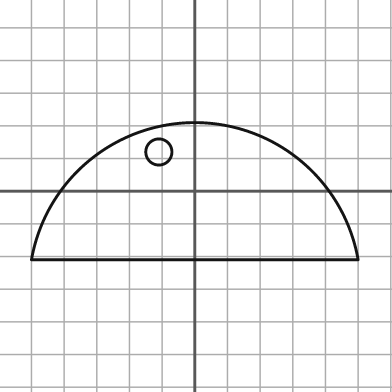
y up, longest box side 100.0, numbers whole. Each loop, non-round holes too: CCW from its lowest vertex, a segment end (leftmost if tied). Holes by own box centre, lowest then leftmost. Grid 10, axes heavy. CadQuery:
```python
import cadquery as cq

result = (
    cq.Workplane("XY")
    .moveTo(-50.0, -21.0)
    .lineTo(50.0, -21.0)
    .threePointArc((0.0, 21.0), (-50.0, -21.0))
    .close()
    .moveTo(-11.0, 12.0)
    .circle(4.0)
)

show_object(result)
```